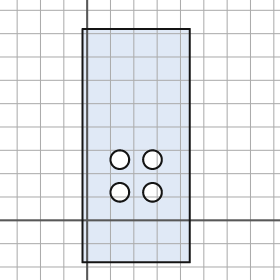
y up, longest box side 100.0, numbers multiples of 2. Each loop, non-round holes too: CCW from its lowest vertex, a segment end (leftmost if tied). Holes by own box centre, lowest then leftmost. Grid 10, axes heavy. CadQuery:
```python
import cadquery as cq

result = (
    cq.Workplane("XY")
    .moveTo(-2.0, -18.0)
    .lineTo(44.0, -18.0)
    .lineTo(44.0, 82.0)
    .lineTo(-2.0, 82.0)
    .close()
    .moveTo(14.0, 12.0)
    .circle(4.0)
    .moveTo(28.0, 12.0)
    .circle(4.0)
    .moveTo(14.0, 26.0)
    .circle(4.0)
    .moveTo(28.0, 26.0)
    .circle(4.0)
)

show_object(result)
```